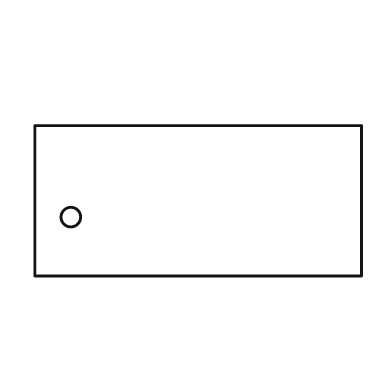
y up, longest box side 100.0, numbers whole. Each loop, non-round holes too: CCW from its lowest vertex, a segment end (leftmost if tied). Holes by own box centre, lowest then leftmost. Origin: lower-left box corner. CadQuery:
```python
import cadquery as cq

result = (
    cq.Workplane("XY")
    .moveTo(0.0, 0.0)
    .lineTo(100.0, 0.0)
    .lineTo(100.0, 46.0)
    .lineTo(0.0, 46.0)
    .close()
    .moveTo(11.0, 18.0)
    .circle(3.0)
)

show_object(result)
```